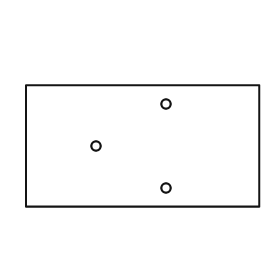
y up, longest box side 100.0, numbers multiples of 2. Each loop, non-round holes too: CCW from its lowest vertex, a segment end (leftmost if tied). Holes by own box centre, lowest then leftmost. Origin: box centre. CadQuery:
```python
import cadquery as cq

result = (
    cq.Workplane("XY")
    .moveTo(-50.0, -26.0)
    .lineTo(50.0, -26.0)
    .lineTo(50.0, 26.0)
    .lineTo(-50.0, 26.0)
    .close()
    .moveTo(10.0, -18.0)
    .circle(2.0)
    .moveTo(-20.0, 0.0)
    .circle(2.0)
    .moveTo(10.0, 18.0)
    .circle(2.0)
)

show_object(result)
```